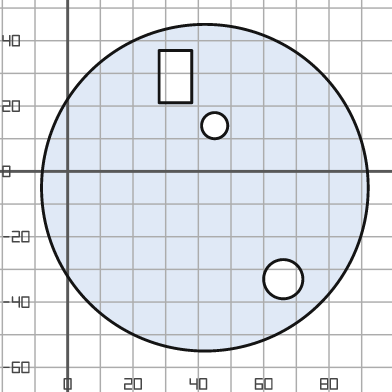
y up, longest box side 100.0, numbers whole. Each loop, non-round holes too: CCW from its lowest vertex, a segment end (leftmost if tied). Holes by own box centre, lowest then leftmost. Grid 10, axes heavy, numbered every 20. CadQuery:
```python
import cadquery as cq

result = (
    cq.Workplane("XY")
    .moveTo(42.0, -5.0)
    .circle(50.0)
    .moveTo(66.0, -33.0)
    .circle(6.0)
    .moveTo(45.0, 14.0)
    .circle(4.0)
    .moveTo(28.0, 21.0)
    .lineTo(38.0, 21.0)
    .lineTo(38.0, 37.0)
    .lineTo(28.0, 37.0)
    .close()
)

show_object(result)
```